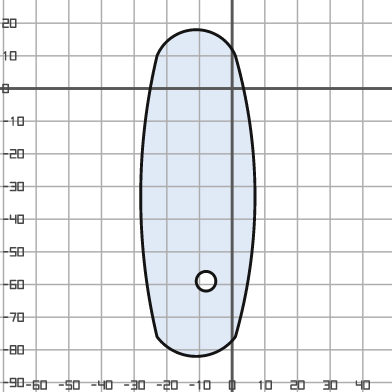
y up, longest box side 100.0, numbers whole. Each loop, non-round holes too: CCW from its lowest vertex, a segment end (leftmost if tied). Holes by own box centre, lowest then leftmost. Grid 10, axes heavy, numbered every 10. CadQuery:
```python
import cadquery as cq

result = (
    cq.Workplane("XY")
    .moveTo(-23.0, -76.0)
    .threePointArc((-11.0, -82.0), (1.0, -76.0))
    .threePointArc((7.0, -33.0), (1.0, 10.0))
    .threePointArc((-11.0, 18.0), (-23.0, 10.0))
    .threePointArc((-28.0, -33.0), (-23.0, -76.0))
    .close()
    .moveTo(-8.0, -59.0)
    .circle(3.0)
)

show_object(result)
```